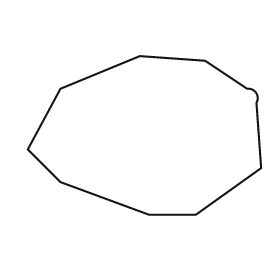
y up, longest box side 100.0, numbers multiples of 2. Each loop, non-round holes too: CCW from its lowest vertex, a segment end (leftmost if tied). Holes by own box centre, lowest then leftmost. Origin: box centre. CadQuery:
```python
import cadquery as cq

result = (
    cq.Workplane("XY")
    .moveTo(2.0, -34.0)
    .lineTo(22.0, -34.0)
    .lineTo(50.0, -14.0)
    .lineTo(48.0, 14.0)
    .threePointArc((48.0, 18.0), (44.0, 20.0))
    .lineTo(26.0, 32.0)
    .lineTo(-2.0, 34.0)
    .lineTo(-36.0, 20.0)
    .lineTo(-50.0, -6.0)
    .lineTo(-36.0, -20.0)
    .close()
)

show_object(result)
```